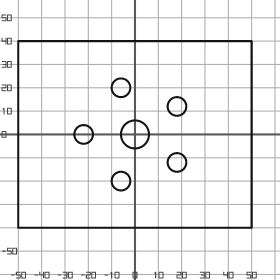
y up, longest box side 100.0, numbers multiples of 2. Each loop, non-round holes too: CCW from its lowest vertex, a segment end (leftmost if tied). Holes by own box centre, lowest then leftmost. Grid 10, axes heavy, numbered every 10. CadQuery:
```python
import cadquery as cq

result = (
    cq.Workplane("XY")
    .moveTo(-50.0, -40.0)
    .lineTo(50.0, -40.0)
    .lineTo(50.0, 40.0)
    .lineTo(-50.0, 40.0)
    .close()
    .moveTo(-6.0, -20.0)
    .circle(4.0)
    .moveTo(18.0, -12.0)
    .circle(4.0)
    .moveTo(-22.0, 0.0)
    .circle(4.0)
    .moveTo(0.0, 0.0)
    .circle(6.0)
    .moveTo(18.0, 12.0)
    .circle(4.0)
    .moveTo(-6.0, 20.0)
    .circle(4.0)
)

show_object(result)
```